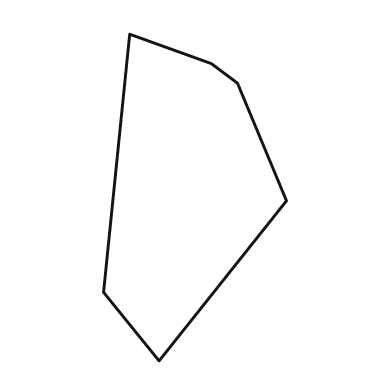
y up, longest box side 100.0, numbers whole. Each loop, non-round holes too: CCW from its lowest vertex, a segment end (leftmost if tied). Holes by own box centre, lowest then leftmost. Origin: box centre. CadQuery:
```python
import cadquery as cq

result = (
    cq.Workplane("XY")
    .moveTo(-11.0, -50.0)
    .lineTo(28.0, -1.0)
    .lineTo(13.0, 35.0)
    .lineTo(5.0, 41.0)
    .lineTo(-20.0, 50.0)
    .lineTo(-28.0, -29.0)
    .close()
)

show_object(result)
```